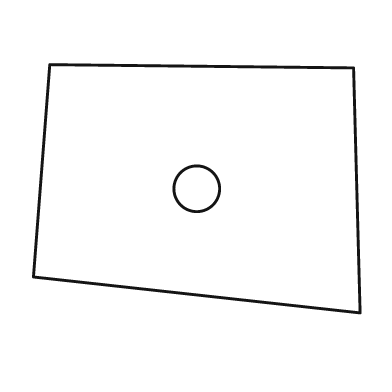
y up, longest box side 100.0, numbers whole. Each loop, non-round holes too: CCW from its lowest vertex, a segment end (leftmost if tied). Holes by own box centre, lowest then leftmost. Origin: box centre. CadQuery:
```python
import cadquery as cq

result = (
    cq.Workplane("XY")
    .moveTo(50.0, -38.0)
    .lineTo(48.0, 37.0)
    .lineTo(-45.0, 38.0)
    .lineTo(-50.0, -27.0)
    .close()
    .moveTo(0.0, 0.0)
    .circle(7.0)
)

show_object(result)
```